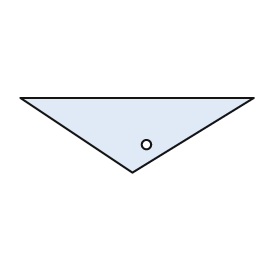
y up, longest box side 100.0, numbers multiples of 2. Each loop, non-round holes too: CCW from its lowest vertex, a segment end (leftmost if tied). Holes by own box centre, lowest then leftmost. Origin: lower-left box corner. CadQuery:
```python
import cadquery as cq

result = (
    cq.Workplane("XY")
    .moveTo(48.0, 0.0)
    .lineTo(100.0, 32.0)
    .lineTo(0.0, 32.0)
    .close()
    .moveTo(54.0, 12.0)
    .circle(2.0)
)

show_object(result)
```